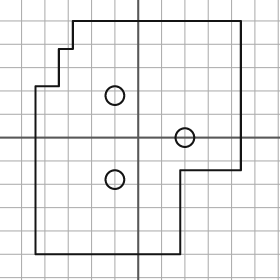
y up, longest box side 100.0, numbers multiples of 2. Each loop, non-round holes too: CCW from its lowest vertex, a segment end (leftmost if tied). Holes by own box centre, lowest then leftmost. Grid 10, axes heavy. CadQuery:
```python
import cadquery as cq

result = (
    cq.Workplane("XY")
    .moveTo(-44.0, -50.0)
    .lineTo(18.0, -50.0)
    .lineTo(18.0, -14.0)
    .lineTo(44.0, -14.0)
    .lineTo(44.0, 50.0)
    .lineTo(-28.0, 50.0)
    .lineTo(-28.0, 38.0)
    .lineTo(-34.0, 38.0)
    .lineTo(-34.0, 22.0)
    .lineTo(-44.0, 22.0)
    .close()
    .moveTo(-10.0, -18.0)
    .circle(4.0)
    .moveTo(20.0, 0.0)
    .circle(4.0)
    .moveTo(-10.0, 18.0)
    .circle(4.0)
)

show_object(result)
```